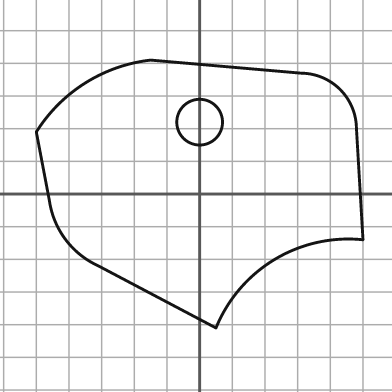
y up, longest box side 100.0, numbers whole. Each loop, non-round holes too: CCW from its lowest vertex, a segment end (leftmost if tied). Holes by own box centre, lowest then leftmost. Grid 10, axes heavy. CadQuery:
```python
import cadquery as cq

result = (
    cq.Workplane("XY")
    .moveTo(5.0, -41.0)
    .threePointArc((23.0, -20.0), (50.0, -14.0))
    .lineTo(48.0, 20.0)
    .threePointArc((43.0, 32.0), (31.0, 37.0))
    .lineTo(-15.0, 41.0)
    .threePointArc((-35.0, 34.0), (-50.0, 19.0))
    .lineTo(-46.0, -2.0)
    .threePointArc((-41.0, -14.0), (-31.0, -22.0))
    .close()
    .moveTo(0.0, 22.0)
    .circle(7.0)
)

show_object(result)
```